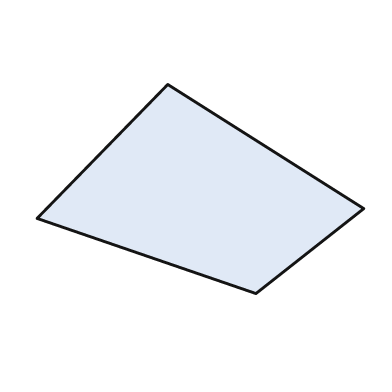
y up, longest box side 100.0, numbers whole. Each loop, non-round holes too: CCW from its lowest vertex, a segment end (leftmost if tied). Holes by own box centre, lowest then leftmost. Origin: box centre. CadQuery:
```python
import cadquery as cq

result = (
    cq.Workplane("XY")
    .moveTo(17.0, -32.0)
    .lineTo(50.0, -6.0)
    .lineTo(-10.0, 32.0)
    .lineTo(-50.0, -9.0)
    .close()
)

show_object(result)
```